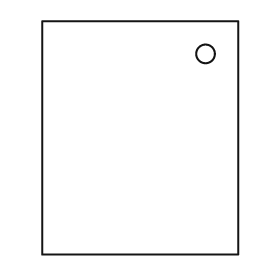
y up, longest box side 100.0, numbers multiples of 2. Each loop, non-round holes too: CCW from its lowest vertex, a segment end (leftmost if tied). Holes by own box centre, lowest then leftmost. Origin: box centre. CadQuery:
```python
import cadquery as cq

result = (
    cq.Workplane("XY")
    .moveTo(-42.0, -50.0)
    .lineTo(42.0, -50.0)
    .lineTo(42.0, 50.0)
    .lineTo(-42.0, 50.0)
    .close()
    .moveTo(28.0, 36.0)
    .circle(4.0)
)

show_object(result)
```